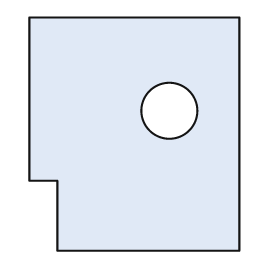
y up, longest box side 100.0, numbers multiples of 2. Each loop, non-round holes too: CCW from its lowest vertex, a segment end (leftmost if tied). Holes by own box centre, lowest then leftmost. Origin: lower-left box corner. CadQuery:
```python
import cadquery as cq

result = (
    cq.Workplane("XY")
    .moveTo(12.0, 0.0)
    .lineTo(90.0, 0.0)
    .lineTo(90.0, 100.0)
    .lineTo(0.0, 100.0)
    .lineTo(0.0, 30.0)
    .lineTo(12.0, 30.0)
    .close()
    .moveTo(60.0, 60.0)
    .circle(12.0)
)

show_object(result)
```